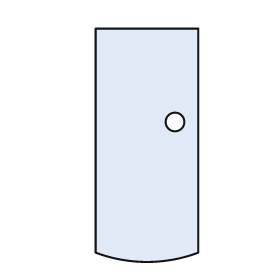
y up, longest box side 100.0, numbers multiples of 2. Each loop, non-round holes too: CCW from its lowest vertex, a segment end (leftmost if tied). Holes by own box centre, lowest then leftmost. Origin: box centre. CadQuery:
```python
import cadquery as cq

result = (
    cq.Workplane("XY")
    .moveTo(-22.0, -46.0)
    .threePointArc((0.0, -50.0), (22.0, -46.0))
    .lineTo(22.0, 50.0)
    .lineTo(-22.0, 50.0)
    .close()
    .moveTo(12.0, 10.0)
    .circle(4.0)
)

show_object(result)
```